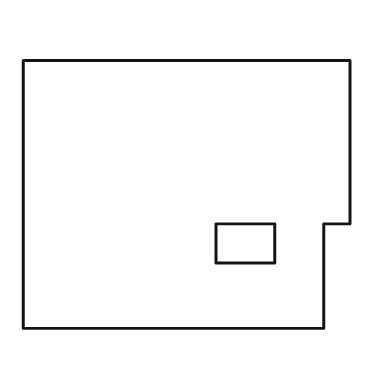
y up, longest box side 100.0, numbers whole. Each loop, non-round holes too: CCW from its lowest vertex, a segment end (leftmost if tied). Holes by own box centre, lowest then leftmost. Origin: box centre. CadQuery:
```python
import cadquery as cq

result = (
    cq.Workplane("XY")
    .moveTo(-50.0, -41.0)
    .lineTo(42.0, -41.0)
    .lineTo(42.0, -9.0)
    .lineTo(50.0, -9.0)
    .lineTo(50.0, 41.0)
    .lineTo(-50.0, 41.0)
    .close()
    .moveTo(9.0, -21.0)
    .lineTo(27.0, -21.0)
    .lineTo(27.0, -9.0)
    .lineTo(9.0, -9.0)
    .close()
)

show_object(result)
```